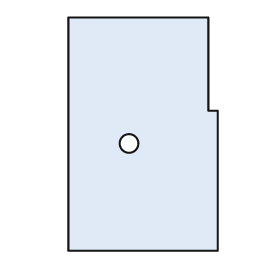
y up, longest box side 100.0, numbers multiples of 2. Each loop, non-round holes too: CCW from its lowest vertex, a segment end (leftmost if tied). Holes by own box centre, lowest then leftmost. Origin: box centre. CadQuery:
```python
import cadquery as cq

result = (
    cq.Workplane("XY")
    .moveTo(-32.0, -50.0)
    .lineTo(32.0, -50.0)
    .lineTo(32.0, 10.0)
    .lineTo(28.0, 10.0)
    .lineTo(28.0, 50.0)
    .lineTo(-32.0, 50.0)
    .close()
    .moveTo(-6.0, -4.0)
    .circle(4.0)
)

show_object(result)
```